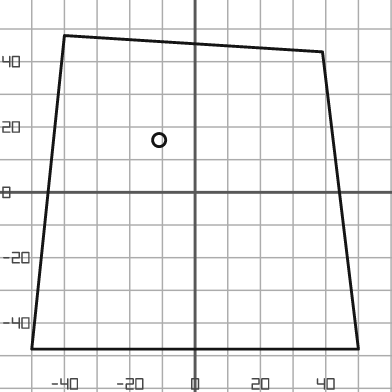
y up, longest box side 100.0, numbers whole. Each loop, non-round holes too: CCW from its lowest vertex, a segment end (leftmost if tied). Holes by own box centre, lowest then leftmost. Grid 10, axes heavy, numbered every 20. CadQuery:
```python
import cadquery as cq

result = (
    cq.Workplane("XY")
    .moveTo(-50.0, -48.0)
    .lineTo(50.0, -48.0)
    .lineTo(39.0, 43.0)
    .lineTo(-40.0, 48.0)
    .close()
    .moveTo(-11.0, 16.0)
    .circle(2.0)
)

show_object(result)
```